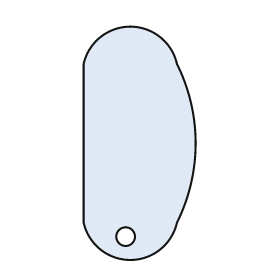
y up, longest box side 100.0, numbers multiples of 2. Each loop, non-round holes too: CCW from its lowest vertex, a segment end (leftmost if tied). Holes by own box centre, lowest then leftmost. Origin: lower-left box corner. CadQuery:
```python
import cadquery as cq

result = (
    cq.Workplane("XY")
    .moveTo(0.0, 16.0)
    .threePointArc((20.0, 0.0), (40.0, 16.0))
    .threePointArc((48.0, 50.0), (40.0, 84.0))
    .threePointArc((20.0, 100.0), (0.0, 84.0))
    .close()
    .moveTo(18.0, 10.0)
    .circle(4.0)
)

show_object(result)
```